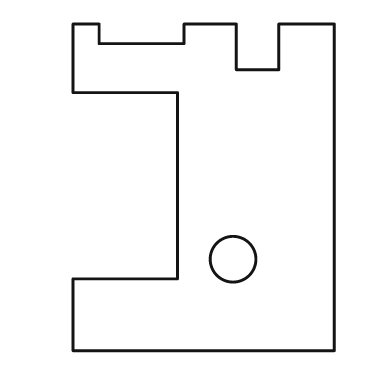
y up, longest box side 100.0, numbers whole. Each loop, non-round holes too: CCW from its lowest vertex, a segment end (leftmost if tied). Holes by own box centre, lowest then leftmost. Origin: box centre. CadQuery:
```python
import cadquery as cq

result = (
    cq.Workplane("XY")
    .moveTo(-40.0, -50.0)
    .lineTo(40.0, -50.0)
    .lineTo(40.0, 50.0)
    .lineTo(23.0, 50.0)
    .lineTo(23.0, 36.0)
    .lineTo(10.0, 36.0)
    .lineTo(10.0, 50.0)
    .lineTo(-6.0, 50.0)
    .lineTo(-6.0, 44.0)
    .lineTo(-32.0, 44.0)
    .lineTo(-32.0, 50.0)
    .lineTo(-40.0, 50.0)
    .lineTo(-40.0, 29.0)
    .lineTo(-8.0, 29.0)
    .lineTo(-8.0, -28.0)
    .lineTo(-40.0, -28.0)
    .close()
    .moveTo(9.0, -22.0)
    .circle(7.0)
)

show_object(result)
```